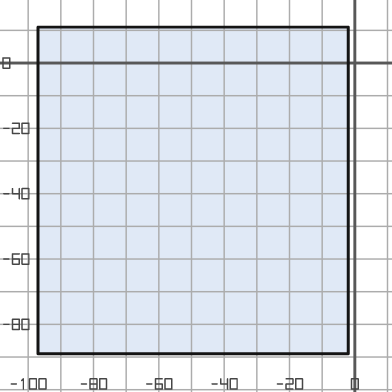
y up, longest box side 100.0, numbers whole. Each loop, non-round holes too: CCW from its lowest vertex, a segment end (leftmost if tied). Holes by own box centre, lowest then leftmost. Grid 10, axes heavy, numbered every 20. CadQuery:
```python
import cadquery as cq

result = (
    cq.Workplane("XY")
    .moveTo(-97.0, -89.0)
    .lineTo(-2.0, -89.0)
    .lineTo(-2.0, 11.0)
    .lineTo(-97.0, 11.0)
    .close()
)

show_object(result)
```